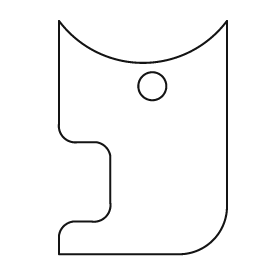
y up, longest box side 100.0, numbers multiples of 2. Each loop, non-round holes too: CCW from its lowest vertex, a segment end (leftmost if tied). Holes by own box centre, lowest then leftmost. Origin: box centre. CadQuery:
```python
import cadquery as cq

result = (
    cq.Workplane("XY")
    .moveTo(-36.0, -50.0)
    .lineTo(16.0, -50.0)
    .threePointArc((30.0, -44.0), (36.0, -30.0))
    .lineTo(36.0, 50.0)
    .threePointArc((0.0, 32.0), (-36.0, 50.0))
    .lineTo(-36.0, 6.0)
    .threePointArc((-34.0, 0.0), (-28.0, -2.0))
    .lineTo(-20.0, -2.0)
    .threePointArc((-16.0, -4.0), (-14.0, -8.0))
    .lineTo(-14.0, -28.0)
    .threePointArc((-16.0, -34.0), (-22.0, -36.0))
    .lineTo(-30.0, -36.0)
    .threePointArc((-34.0, -38.0), (-36.0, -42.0))
    .close()
    .moveTo(4.0, 22.0)
    .circle(6.0)
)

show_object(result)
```